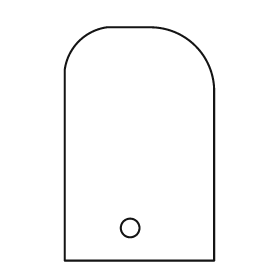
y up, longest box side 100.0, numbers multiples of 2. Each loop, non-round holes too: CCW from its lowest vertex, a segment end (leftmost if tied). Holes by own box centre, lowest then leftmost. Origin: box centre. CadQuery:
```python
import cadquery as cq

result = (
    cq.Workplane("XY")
    .moveTo(-32.0, -50.0)
    .lineTo(32.0, -50.0)
    .lineTo(32.0, 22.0)
    .threePointArc((24.0, 42.0), (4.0, 50.0))
    .lineTo(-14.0, 50.0)
    .threePointArc((-26.0, 44.0), (-32.0, 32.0))
    .close()
    .moveTo(-4.0, -36.0)
    .circle(4.0)
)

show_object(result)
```